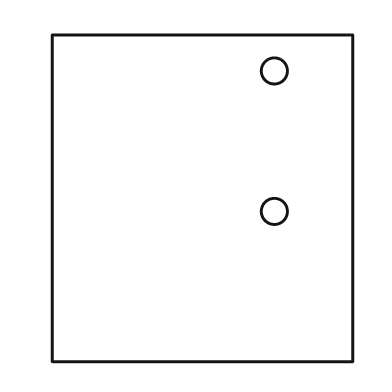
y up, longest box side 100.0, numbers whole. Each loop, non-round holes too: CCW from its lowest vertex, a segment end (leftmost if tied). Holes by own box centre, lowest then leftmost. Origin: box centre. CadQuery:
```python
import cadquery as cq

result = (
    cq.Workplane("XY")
    .moveTo(-46.0, -50.0)
    .lineTo(46.0, -50.0)
    .lineTo(46.0, 50.0)
    .lineTo(-46.0, 50.0)
    .close()
    .moveTo(22.0, -4.0)
    .circle(4.0)
    .moveTo(22.0, 39.0)
    .circle(4.0)
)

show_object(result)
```